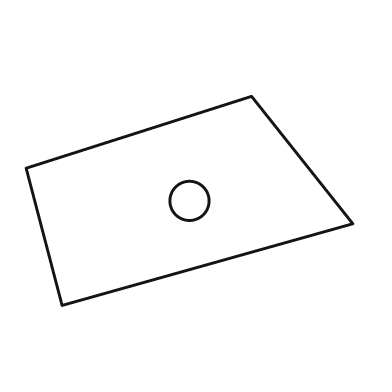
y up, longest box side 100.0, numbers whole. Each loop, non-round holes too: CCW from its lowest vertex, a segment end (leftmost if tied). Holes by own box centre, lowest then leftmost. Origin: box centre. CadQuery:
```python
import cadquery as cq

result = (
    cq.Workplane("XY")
    .moveTo(-39.0, -32.0)
    .lineTo(50.0, -7.0)
    .lineTo(19.0, 32.0)
    .lineTo(-50.0, 10.0)
    .close()
    .moveTo(0.0, 0.0)
    .circle(6.0)
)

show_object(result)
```